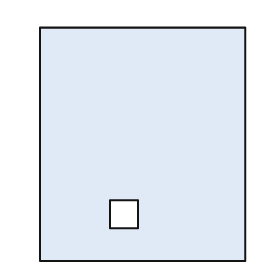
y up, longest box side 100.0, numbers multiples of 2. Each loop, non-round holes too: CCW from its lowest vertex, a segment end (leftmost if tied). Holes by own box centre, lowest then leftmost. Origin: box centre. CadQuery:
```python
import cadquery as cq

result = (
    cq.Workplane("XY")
    .moveTo(-44.0, -50.0)
    .lineTo(44.0, -50.0)
    .lineTo(44.0, 50.0)
    .lineTo(-44.0, 50.0)
    .close()
    .moveTo(-14.0, -36.0)
    .lineTo(-2.0, -36.0)
    .lineTo(-2.0, -24.0)
    .lineTo(-14.0, -24.0)
    .close()
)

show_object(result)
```